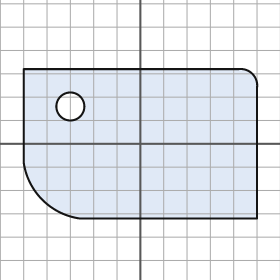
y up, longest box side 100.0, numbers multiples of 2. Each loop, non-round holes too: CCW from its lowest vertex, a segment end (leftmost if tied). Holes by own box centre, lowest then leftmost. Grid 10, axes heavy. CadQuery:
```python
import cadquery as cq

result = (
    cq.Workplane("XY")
    .moveTo(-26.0, -32.0)
    .lineTo(50.0, -32.0)
    .lineTo(50.0, 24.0)
    .threePointArc((48.0, 30.0), (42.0, 32.0))
    .lineTo(-50.0, 32.0)
    .lineTo(-50.0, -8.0)
    .threePointArc((-42.0, -24.0), (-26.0, -32.0))
    .close()
    .moveTo(-30.0, 16.0)
    .circle(6.0)
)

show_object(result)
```